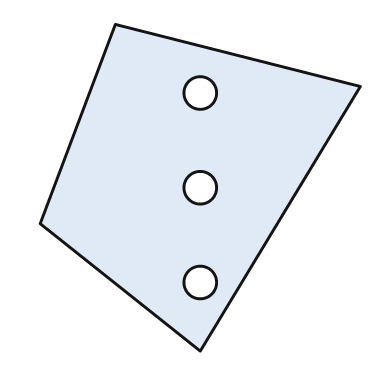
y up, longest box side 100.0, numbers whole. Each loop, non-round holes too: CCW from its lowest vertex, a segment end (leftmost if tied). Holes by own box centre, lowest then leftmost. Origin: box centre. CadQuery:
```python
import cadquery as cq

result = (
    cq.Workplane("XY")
    .moveTo(0.0, -50.0)
    .lineTo(49.0, 31.0)
    .lineTo(-26.0, 50.0)
    .lineTo(-49.0, -11.0)
    .close()
    .moveTo(0.0, -29.0)
    .circle(5.0)
    .moveTo(0.0, 0.0)
    .circle(5.0)
    .moveTo(0.0, 29.0)
    .circle(5.0)
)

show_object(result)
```